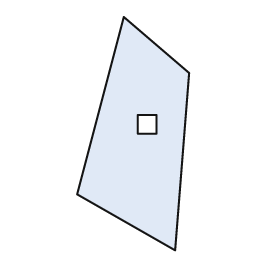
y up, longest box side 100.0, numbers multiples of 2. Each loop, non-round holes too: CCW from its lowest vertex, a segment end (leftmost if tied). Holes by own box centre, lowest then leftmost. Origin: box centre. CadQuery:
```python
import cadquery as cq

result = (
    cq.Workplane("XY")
    .moveTo(18.0, -50.0)
    .lineTo(24.0, 26.0)
    .lineTo(-4.0, 50.0)
    .lineTo(-24.0, -26.0)
    .close()
    .moveTo(2.0, 0.0)
    .lineTo(10.0, 0.0)
    .lineTo(10.0, 8.0)
    .lineTo(2.0, 8.0)
    .close()
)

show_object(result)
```